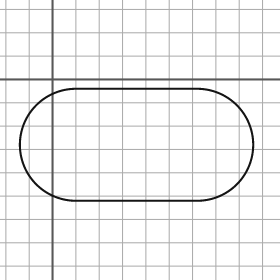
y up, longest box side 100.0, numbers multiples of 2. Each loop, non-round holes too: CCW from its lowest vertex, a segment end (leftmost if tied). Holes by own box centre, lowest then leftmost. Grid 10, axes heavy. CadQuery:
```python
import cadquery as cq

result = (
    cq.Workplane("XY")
    .moveTo(10.0, -52.0)
    .lineTo(62.0, -52.0)
    .threePointArc((86.0, -28.0), (62.0, -4.0))
    .lineTo(10.0, -4.0)
    .threePointArc((-14.0, -28.0), (10.0, -52.0))
    .close()
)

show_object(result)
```